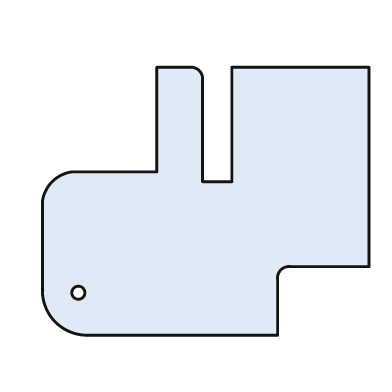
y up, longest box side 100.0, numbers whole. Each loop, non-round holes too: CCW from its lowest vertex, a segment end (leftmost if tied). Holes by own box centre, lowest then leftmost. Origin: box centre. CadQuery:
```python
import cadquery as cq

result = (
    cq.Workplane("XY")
    .moveTo(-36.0, -41.0)
    .lineTo(22.0, -41.0)
    .lineTo(22.0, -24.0)
    .threePointArc((23.0, -21.0), (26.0, -20.0))
    .lineTo(50.0, -20.0)
    .lineTo(50.0, 41.0)
    .lineTo(8.0, 41.0)
    .lineTo(8.0, 6.0)
    .lineTo(-1.0, 6.0)
    .lineTo(-1.0, 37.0)
    .threePointArc((-2.0, 40.0), (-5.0, 41.0))
    .lineTo(-15.0, 41.0)
    .lineTo(-15.0, 9.0)
    .lineTo(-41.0, 9.0)
    .threePointArc((-47.0, 6.0), (-50.0, 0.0))
    .lineTo(-50.0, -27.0)
    .threePointArc((-46.0, -37.0), (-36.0, -41.0))
    .close()
    .moveTo(-39.0, -28.0)
    .circle(2.0)
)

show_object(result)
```